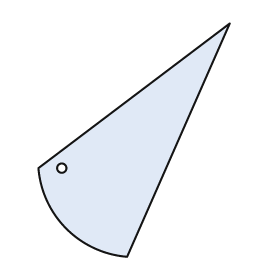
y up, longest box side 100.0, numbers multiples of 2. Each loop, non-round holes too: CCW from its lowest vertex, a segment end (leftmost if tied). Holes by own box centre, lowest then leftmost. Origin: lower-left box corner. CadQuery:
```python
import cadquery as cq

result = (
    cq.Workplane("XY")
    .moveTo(38.0, 0.0)
    .lineTo(82.0, 100.0)
    .lineTo(0.0, 38.0)
    .threePointArc((12.0, 12.0), (38.0, 0.0))
    .close()
    .moveTo(10.0, 38.0)
    .circle(2.0)
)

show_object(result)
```